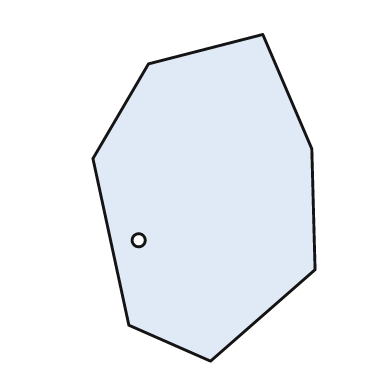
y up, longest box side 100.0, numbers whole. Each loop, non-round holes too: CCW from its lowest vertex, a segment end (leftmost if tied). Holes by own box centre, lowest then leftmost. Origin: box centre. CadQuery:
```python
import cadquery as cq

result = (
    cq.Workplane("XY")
    .moveTo(2.0, -50.0)
    .lineTo(34.0, -22.0)
    .lineTo(33.0, 15.0)
    .lineTo(18.0, 50.0)
    .lineTo(-17.0, 41.0)
    .lineTo(-34.0, 12.0)
    .lineTo(-23.0, -39.0)
    .close()
    .moveTo(-20.0, -13.0)
    .circle(2.0)
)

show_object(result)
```